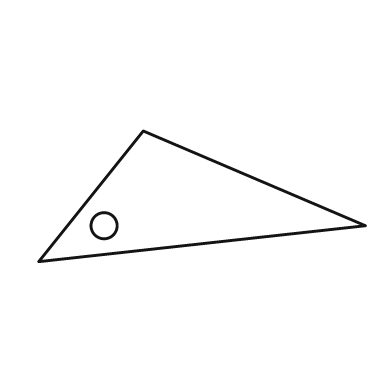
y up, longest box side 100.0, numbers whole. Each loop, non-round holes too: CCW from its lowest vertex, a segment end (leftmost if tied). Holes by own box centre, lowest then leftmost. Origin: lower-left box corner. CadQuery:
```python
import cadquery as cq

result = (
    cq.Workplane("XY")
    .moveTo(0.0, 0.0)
    .lineTo(100.0, 11.0)
    .lineTo(32.0, 40.0)
    .close()
    .moveTo(20.0, 11.0)
    .circle(4.0)
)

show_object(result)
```